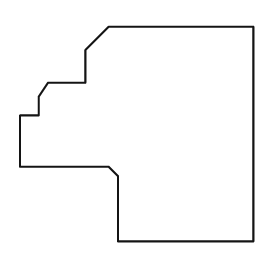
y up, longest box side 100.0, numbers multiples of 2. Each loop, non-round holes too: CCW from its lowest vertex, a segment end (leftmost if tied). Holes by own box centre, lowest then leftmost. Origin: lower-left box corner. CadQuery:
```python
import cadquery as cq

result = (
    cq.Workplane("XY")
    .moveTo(42.0, 0.0)
    .lineTo(100.0, 0.0)
    .lineTo(100.0, 92.0)
    .lineTo(38.0, 92.0)
    .lineTo(28.0, 82.0)
    .lineTo(28.0, 68.0)
    .lineTo(12.0, 68.0)
    .lineTo(8.0, 62.0)
    .lineTo(8.0, 54.0)
    .lineTo(0.0, 54.0)
    .lineTo(0.0, 32.0)
    .lineTo(38.0, 32.0)
    .lineTo(42.0, 28.0)
    .close()
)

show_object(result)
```